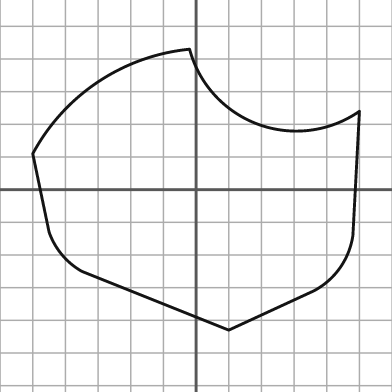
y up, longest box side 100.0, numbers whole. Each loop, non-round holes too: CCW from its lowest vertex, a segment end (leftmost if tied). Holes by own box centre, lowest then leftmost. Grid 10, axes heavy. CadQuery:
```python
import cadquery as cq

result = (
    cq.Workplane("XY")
    .moveTo(10.0, -43.0)
    .lineTo(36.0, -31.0)
    .threePointArc((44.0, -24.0), (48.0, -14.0))
    .lineTo(50.0, 24.0)
    .threePointArc((19.0, 20.0), (-2.0, 43.0))
    .threePointArc((-30.0, 33.0), (-50.0, 11.0))
    .lineTo(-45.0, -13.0)
    .threePointArc((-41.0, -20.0), (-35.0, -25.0))
    .close()
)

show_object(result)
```